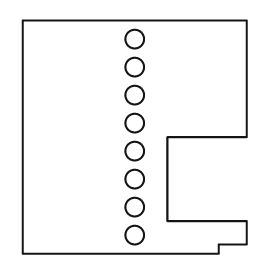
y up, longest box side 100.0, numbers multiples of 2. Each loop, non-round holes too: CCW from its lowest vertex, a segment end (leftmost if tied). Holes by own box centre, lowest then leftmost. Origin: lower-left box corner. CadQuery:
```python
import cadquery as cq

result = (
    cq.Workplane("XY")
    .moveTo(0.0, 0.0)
    .lineTo(84.0, 0.0)
    .lineTo(84.0, 4.0)
    .lineTo(96.0, 4.0)
    .lineTo(96.0, 14.0)
    .lineTo(62.0, 14.0)
    .lineTo(62.0, 50.0)
    .lineTo(96.0, 50.0)
    .lineTo(96.0, 100.0)
    .lineTo(0.0, 100.0)
    .close()
    .moveTo(48.0, 8.0)
    .circle(4.0)
    .moveTo(48.0, 20.0)
    .circle(4.0)
    .moveTo(48.0, 32.0)
    .circle(4.0)
    .moveTo(48.0, 44.0)
    .circle(4.0)
    .moveTo(48.0, 56.0)
    .circle(4.0)
    .moveTo(48.0, 68.0)
    .circle(4.0)
    .moveTo(48.0, 80.0)
    .circle(4.0)
    .moveTo(48.0, 92.0)
    .circle(4.0)
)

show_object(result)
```